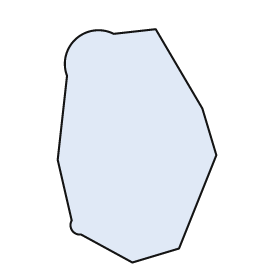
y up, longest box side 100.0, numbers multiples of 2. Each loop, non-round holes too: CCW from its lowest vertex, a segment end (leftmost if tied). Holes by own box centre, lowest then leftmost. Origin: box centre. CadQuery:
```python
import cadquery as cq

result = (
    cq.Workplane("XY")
    .moveTo(-2.0, -50.0)
    .lineTo(18.0, -44.0)
    .lineTo(34.0, -4.0)
    .lineTo(28.0, 16.0)
    .lineTo(8.0, 50.0)
    .lineTo(-10.0, 48.0)
    .threePointArc((-26.0, 46.0), (-30.0, 30.0))
    .lineTo(-34.0, -6.0)
    .lineTo(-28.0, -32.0)
    .threePointArc((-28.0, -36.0), (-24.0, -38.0))
    .close()
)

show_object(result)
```